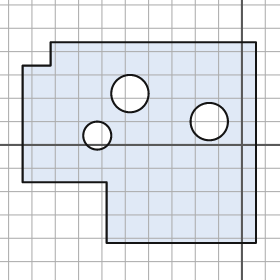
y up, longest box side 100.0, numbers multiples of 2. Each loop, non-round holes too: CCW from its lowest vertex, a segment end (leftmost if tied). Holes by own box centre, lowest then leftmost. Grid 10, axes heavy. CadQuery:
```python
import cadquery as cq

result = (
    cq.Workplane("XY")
    .moveTo(-58.0, -42.0)
    .lineTo(6.0, -42.0)
    .lineTo(6.0, 44.0)
    .lineTo(-82.0, 44.0)
    .lineTo(-82.0, 34.0)
    .lineTo(-94.0, 34.0)
    .lineTo(-94.0, -16.0)
    .lineTo(-58.0, -16.0)
    .close()
    .moveTo(-62.0, 4.0)
    .circle(6.0)
    .moveTo(-14.0, 10.0)
    .circle(8.0)
    .moveTo(-48.0, 22.0)
    .circle(8.0)
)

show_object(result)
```